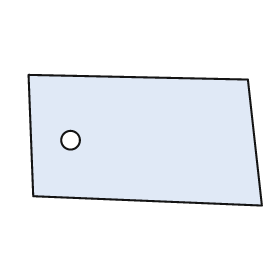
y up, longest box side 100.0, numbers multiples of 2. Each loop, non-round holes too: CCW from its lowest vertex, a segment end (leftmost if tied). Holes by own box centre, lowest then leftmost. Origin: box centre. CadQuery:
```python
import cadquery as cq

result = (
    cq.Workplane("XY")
    .moveTo(50.0, -28.0)
    .lineTo(44.0, 26.0)
    .lineTo(-50.0, 28.0)
    .lineTo(-48.0, -24.0)
    .close()
    .moveTo(-32.0, 0.0)
    .circle(4.0)
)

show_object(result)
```